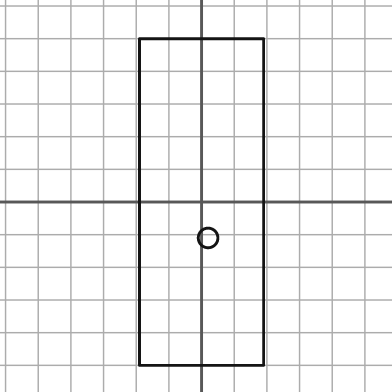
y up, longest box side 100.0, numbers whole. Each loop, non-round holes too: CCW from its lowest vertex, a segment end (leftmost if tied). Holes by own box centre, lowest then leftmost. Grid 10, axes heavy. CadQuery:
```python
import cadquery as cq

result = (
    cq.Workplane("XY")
    .moveTo(-19.0, -50.0)
    .lineTo(19.0, -50.0)
    .lineTo(19.0, 50.0)
    .lineTo(-19.0, 50.0)
    .close()
    .moveTo(2.0, -11.0)
    .circle(3.0)
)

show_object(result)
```